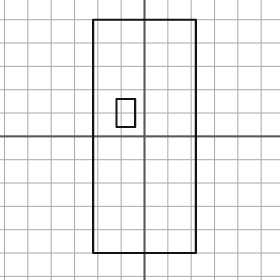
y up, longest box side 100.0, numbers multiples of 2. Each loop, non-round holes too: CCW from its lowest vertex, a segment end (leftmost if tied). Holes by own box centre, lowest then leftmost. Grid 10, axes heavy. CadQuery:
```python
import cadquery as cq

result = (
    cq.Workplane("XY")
    .moveTo(-22.0, -50.0)
    .lineTo(22.0, -50.0)
    .lineTo(22.0, 50.0)
    .lineTo(-22.0, 50.0)
    .close()
    .moveTo(-12.0, 4.0)
    .lineTo(-4.0, 4.0)
    .lineTo(-4.0, 16.0)
    .lineTo(-12.0, 16.0)
    .close()
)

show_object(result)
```